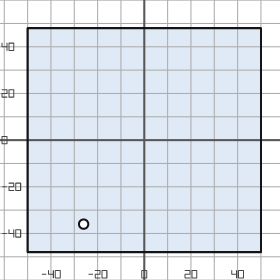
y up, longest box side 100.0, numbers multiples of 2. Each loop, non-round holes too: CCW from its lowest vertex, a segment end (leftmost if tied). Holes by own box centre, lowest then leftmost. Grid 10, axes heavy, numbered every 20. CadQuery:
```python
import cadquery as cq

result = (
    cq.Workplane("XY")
    .moveTo(-50.0, -48.0)
    .lineTo(50.0, -48.0)
    .lineTo(50.0, 48.0)
    .lineTo(-50.0, 48.0)
    .close()
    .moveTo(-26.0, -36.0)
    .circle(2.0)
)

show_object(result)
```